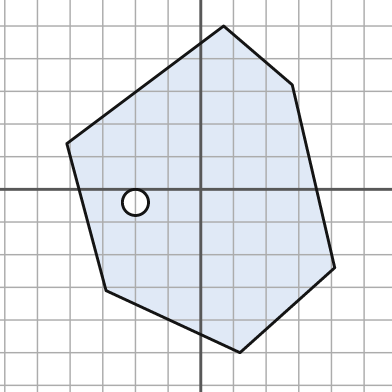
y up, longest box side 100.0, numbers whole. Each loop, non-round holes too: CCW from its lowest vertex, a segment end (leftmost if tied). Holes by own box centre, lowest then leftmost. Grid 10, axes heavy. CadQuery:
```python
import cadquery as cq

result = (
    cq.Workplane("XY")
    .moveTo(12.0, -50.0)
    .lineTo(41.0, -24.0)
    .lineTo(28.0, 32.0)
    .lineTo(7.0, 50.0)
    .lineTo(-41.0, 14.0)
    .lineTo(-29.0, -31.0)
    .close()
    .moveTo(-20.0, -4.0)
    .circle(4.0)
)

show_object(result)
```